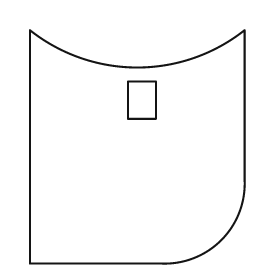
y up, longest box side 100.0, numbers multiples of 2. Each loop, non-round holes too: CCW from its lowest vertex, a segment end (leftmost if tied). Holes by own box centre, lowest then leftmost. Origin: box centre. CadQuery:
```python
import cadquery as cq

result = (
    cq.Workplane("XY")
    .moveTo(-46.0, -50.0)
    .lineTo(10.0, -50.0)
    .threePointArc((36.0, -40.0), (46.0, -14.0))
    .lineTo(46.0, 50.0)
    .threePointArc((0.0, 34.0), (-46.0, 50.0))
    .close()
    .moveTo(-4.0, 12.0)
    .lineTo(8.0, 12.0)
    .lineTo(8.0, 28.0)
    .lineTo(-4.0, 28.0)
    .close()
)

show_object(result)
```